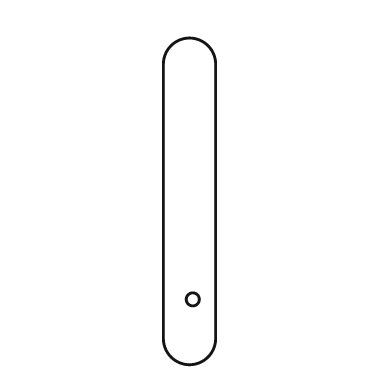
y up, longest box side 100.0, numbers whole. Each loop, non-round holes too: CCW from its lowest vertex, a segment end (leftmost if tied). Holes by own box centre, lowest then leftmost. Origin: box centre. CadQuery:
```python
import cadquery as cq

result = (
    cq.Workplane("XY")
    .moveTo(-8.0, -42.0)
    .threePointArc((0.0, -50.0), (8.0, -42.0))
    .lineTo(8.0, 42.0)
    .threePointArc((0.0, 50.0), (-8.0, 42.0))
    .close()
    .moveTo(1.0, -30.0)
    .circle(2.0)
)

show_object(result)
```